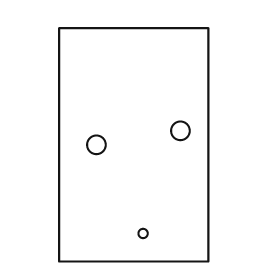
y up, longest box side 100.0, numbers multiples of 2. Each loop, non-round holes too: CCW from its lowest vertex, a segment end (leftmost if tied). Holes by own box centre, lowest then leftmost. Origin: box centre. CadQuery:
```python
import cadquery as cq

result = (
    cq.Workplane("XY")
    .moveTo(-32.0, -50.0)
    .lineTo(32.0, -50.0)
    .lineTo(32.0, 50.0)
    .lineTo(-32.0, 50.0)
    .close()
    .moveTo(4.0, -38.0)
    .circle(2.0)
    .moveTo(-16.0, 0.0)
    .circle(4.0)
    .moveTo(20.0, 6.0)
    .circle(4.0)
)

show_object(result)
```